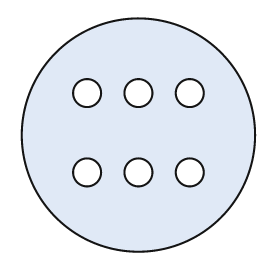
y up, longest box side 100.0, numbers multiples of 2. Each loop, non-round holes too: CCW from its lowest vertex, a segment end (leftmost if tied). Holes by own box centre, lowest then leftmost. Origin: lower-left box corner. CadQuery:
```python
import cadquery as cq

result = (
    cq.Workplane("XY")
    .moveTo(50.0, 50.0)
    .circle(50.0)
    .moveTo(28.0, 34.0)
    .circle(6.0)
    .moveTo(50.0, 34.0)
    .circle(6.0)
    .moveTo(72.0, 34.0)
    .circle(6.0)
    .moveTo(28.0, 68.0)
    .circle(6.0)
    .moveTo(50.0, 68.0)
    .circle(6.0)
    .moveTo(72.0, 68.0)
    .circle(6.0)
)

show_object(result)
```